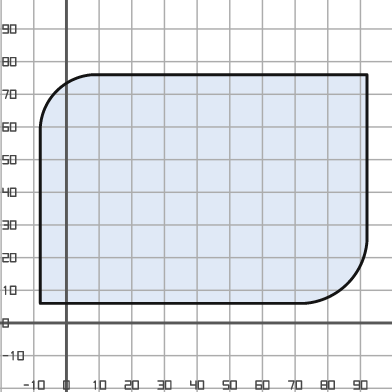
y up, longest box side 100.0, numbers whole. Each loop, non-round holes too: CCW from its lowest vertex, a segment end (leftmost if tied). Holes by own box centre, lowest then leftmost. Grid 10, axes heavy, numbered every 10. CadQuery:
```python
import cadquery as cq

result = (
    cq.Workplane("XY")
    .moveTo(-8.0, 6.0)
    .lineTo(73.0, 6.0)
    .threePointArc((86.0, 12.0), (92.0, 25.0))
    .lineTo(92.0, 76.0)
    .lineTo(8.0, 76.0)
    .threePointArc((-3.0, 71.0), (-8.0, 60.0))
    .close()
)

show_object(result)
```